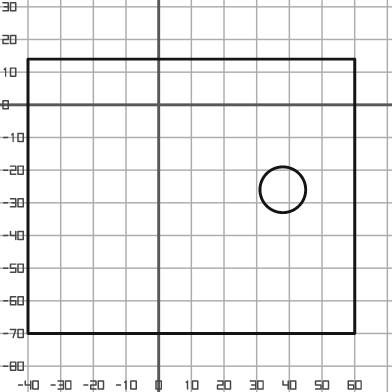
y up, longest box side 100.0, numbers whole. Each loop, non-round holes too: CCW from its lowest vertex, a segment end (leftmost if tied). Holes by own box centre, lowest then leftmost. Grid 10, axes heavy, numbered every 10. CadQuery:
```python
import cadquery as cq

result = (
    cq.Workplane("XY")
    .moveTo(-40.0, -70.0)
    .lineTo(60.0, -70.0)
    .lineTo(60.0, 14.0)
    .lineTo(-40.0, 14.0)
    .close()
    .moveTo(38.0, -26.0)
    .circle(7.0)
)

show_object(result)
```